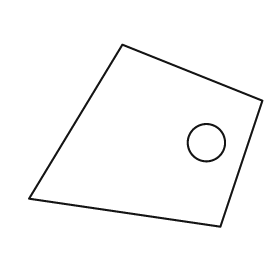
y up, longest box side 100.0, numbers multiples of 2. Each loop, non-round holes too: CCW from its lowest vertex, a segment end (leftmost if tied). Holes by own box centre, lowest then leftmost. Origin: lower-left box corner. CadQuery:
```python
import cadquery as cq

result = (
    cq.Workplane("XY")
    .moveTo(82.0, 0.0)
    .lineTo(100.0, 54.0)
    .lineTo(40.0, 78.0)
    .lineTo(0.0, 12.0)
    .close()
    .moveTo(76.0, 36.0)
    .circle(8.0)
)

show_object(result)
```